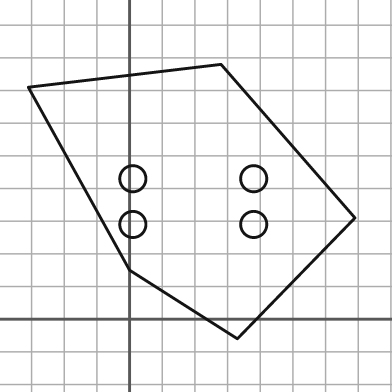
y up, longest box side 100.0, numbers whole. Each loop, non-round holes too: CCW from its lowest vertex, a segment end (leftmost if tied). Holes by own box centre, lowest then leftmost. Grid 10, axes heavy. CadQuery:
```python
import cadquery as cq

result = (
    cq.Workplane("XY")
    .moveTo(33.0, -6.0)
    .lineTo(69.0, 31.0)
    .lineTo(28.0, 78.0)
    .lineTo(-31.0, 71.0)
    .lineTo(0.0, 15.0)
    .close()
    .moveTo(1.0, 29.0)
    .circle(4.0)
    .moveTo(38.0, 29.0)
    .circle(4.0)
    .moveTo(1.0, 43.0)
    .circle(4.0)
    .moveTo(38.0, 43.0)
    .circle(4.0)
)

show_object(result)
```